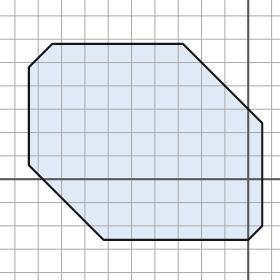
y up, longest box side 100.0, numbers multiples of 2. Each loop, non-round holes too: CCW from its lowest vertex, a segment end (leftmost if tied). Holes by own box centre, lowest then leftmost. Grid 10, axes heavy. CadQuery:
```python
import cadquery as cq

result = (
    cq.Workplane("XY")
    .moveTo(-62.0, -26.0)
    .lineTo(0.0, -26.0)
    .lineTo(6.0, -20.0)
    .lineTo(6.0, 24.0)
    .lineTo(-28.0, 58.0)
    .lineTo(-84.0, 58.0)
    .lineTo(-94.0, 48.0)
    .lineTo(-94.0, 6.0)
    .close()
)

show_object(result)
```